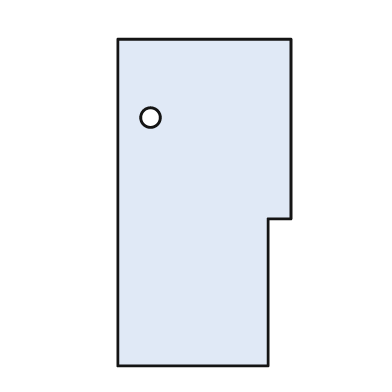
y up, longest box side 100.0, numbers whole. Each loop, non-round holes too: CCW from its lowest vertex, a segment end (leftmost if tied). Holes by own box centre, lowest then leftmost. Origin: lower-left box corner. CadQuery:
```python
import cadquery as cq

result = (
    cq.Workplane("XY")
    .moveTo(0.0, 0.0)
    .lineTo(46.0, 0.0)
    .lineTo(46.0, 45.0)
    .lineTo(53.0, 45.0)
    .lineTo(53.0, 100.0)
    .lineTo(0.0, 100.0)
    .close()
    .moveTo(10.0, 76.0)
    .circle(3.0)
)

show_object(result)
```